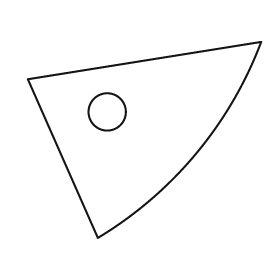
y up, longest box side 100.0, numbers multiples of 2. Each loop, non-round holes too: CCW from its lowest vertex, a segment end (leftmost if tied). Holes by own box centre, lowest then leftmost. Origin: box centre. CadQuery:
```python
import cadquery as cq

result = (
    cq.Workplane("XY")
    .moveTo(-20.0, -42.0)
    .threePointArc((22.0, -6.0), (50.0, 42.0))
    .lineTo(-50.0, 26.0)
    .close()
    .moveTo(-16.0, 12.0)
    .circle(8.0)
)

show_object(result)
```